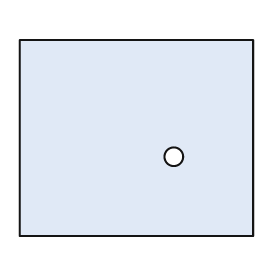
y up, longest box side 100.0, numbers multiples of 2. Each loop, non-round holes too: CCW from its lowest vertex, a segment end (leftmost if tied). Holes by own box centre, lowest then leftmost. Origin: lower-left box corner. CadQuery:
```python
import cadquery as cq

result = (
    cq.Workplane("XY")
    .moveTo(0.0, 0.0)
    .lineTo(100.0, 0.0)
    .lineTo(100.0, 84.0)
    .lineTo(0.0, 84.0)
    .close()
    .moveTo(66.0, 34.0)
    .circle(4.0)
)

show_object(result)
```